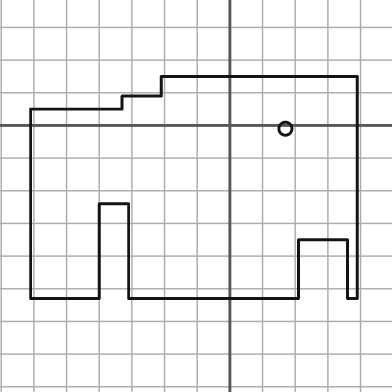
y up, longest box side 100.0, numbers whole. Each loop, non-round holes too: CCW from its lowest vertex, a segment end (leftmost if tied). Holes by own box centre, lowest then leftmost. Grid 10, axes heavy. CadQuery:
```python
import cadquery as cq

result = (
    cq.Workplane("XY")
    .moveTo(-61.0, -53.0)
    .lineTo(-40.0, -53.0)
    .lineTo(-40.0, -24.0)
    .lineTo(-31.0, -24.0)
    .lineTo(-31.0, -53.0)
    .lineTo(21.0, -53.0)
    .lineTo(21.0, -35.0)
    .lineTo(36.0, -35.0)
    .lineTo(36.0, -53.0)
    .lineTo(39.0, -53.0)
    .lineTo(39.0, 15.0)
    .lineTo(-21.0, 15.0)
    .lineTo(-21.0, 9.0)
    .lineTo(-33.0, 9.0)
    .lineTo(-33.0, 5.0)
    .lineTo(-61.0, 5.0)
    .close()
    .moveTo(17.0, -1.0)
    .circle(2.0)
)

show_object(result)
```